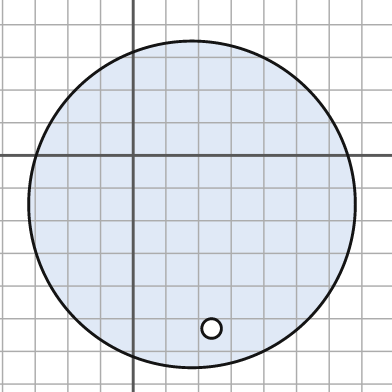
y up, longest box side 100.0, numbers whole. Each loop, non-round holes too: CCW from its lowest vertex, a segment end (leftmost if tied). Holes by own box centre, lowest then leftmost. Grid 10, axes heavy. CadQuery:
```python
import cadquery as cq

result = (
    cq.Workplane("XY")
    .moveTo(18.0, -15.0)
    .circle(50.0)
    .moveTo(24.0, -53.0)
    .circle(3.0)
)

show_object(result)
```